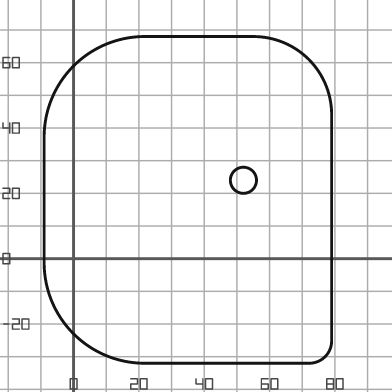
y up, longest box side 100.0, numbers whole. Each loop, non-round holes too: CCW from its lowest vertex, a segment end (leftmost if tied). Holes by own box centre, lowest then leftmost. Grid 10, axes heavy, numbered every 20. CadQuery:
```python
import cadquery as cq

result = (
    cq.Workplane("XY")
    .moveTo(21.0, -32.0)
    .lineTo(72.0, -32.0)
    .threePointArc((77.0, -30.0), (79.0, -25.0))
    .lineTo(79.0, 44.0)
    .threePointArc((72.0, 61.0), (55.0, 68.0))
    .lineTo(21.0, 68.0)
    .threePointArc((0.0, 59.0), (-9.0, 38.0))
    .lineTo(-9.0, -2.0)
    .threePointArc((0.0, -23.0), (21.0, -32.0))
    .close()
    .moveTo(52.0, 24.0)
    .circle(4.0)
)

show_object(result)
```